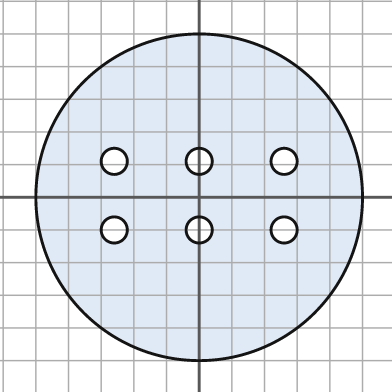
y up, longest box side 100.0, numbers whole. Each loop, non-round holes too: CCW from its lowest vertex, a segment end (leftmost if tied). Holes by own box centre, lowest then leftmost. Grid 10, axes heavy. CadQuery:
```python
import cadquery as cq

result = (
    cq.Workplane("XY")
    .moveTo(0.0, 0.0)
    .circle(50.0)
    .moveTo(-26.0, -10.0)
    .circle(4.0)
    .moveTo(0.0, -10.0)
    .circle(4.0)
    .moveTo(26.0, -10.0)
    .circle(4.0)
    .moveTo(-26.0, 11.0)
    .circle(4.0)
    .moveTo(0.0, 11.0)
    .circle(4.0)
    .moveTo(26.0, 11.0)
    .circle(4.0)
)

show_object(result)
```